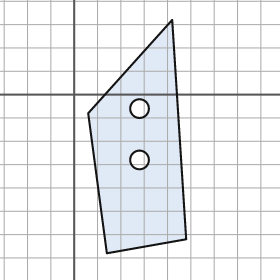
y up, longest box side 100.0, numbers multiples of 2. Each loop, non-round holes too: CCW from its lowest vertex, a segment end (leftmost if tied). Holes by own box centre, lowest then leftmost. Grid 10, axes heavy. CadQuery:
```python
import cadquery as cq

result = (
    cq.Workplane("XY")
    .moveTo(14.0, -68.0)
    .lineTo(48.0, -62.0)
    .lineTo(42.0, 32.0)
    .lineTo(6.0, -8.0)
    .close()
    .moveTo(28.0, -28.0)
    .circle(4.0)
    .moveTo(28.0, -6.0)
    .circle(4.0)
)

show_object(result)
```